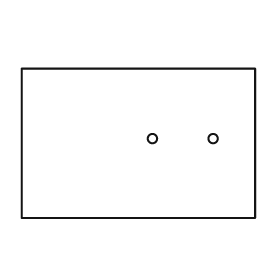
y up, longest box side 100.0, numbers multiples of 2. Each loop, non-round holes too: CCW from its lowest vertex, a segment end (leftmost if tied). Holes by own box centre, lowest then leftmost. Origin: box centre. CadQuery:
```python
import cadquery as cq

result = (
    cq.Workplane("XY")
    .moveTo(-50.0, -32.0)
    .lineTo(50.0, -32.0)
    .lineTo(50.0, 32.0)
    .lineTo(-50.0, 32.0)
    .close()
    .moveTo(6.0, 2.0)
    .circle(2.0)
    .moveTo(32.0, 2.0)
    .circle(2.0)
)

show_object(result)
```